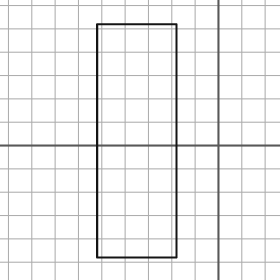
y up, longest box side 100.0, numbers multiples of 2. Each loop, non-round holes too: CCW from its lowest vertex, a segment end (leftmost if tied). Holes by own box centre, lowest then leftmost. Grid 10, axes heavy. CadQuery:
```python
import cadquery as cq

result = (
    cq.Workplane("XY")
    .moveTo(-52.0, -48.0)
    .lineTo(-18.0, -48.0)
    .lineTo(-18.0, 52.0)
    .lineTo(-52.0, 52.0)
    .close()
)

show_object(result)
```